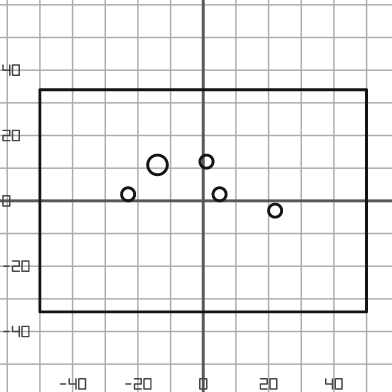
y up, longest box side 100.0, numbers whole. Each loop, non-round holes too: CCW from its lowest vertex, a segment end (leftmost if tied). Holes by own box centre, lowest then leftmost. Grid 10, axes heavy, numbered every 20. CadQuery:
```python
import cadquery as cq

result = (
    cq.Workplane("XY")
    .moveTo(-50.0, -34.0)
    .lineTo(50.0, -34.0)
    .lineTo(50.0, 34.0)
    .lineTo(-50.0, 34.0)
    .close()
    .moveTo(22.0, -3.0)
    .circle(2.0)
    .moveTo(-23.0, 2.0)
    .circle(2.0)
    .moveTo(5.0, 2.0)
    .circle(2.0)
    .moveTo(-14.0, 11.0)
    .circle(3.0)
    .moveTo(1.0, 12.0)
    .circle(2.0)
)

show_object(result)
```